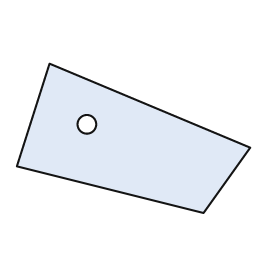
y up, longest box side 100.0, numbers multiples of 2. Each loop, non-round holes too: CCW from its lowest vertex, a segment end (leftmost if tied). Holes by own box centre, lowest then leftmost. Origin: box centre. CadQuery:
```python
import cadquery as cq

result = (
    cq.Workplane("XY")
    .moveTo(30.0, -32.0)
    .lineTo(50.0, -4.0)
    .lineTo(-36.0, 32.0)
    .lineTo(-50.0, -12.0)
    .close()
    .moveTo(-20.0, 6.0)
    .circle(4.0)
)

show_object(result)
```